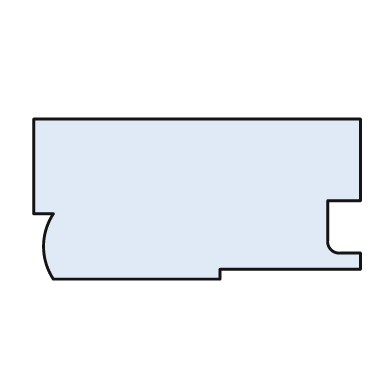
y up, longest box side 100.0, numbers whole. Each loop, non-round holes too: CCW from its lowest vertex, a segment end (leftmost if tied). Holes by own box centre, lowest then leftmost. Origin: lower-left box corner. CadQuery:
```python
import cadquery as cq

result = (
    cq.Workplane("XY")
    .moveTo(6.0, 0.0)
    .lineTo(57.0, 0.0)
    .lineTo(57.0, 3.0)
    .lineTo(100.0, 3.0)
    .lineTo(100.0, 8.0)
    .lineTo(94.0, 8.0)
    .threePointArc((91.0, 9.0), (90.0, 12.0))
    .lineTo(90.0, 24.0)
    .lineTo(100.0, 24.0)
    .lineTo(100.0, 49.0)
    .lineTo(0.0, 49.0)
    .lineTo(0.0, 20.0)
    .lineTo(6.0, 20.0)
    .threePointArc((3.0, 10.0), (6.0, 0.0))
    .close()
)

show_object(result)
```